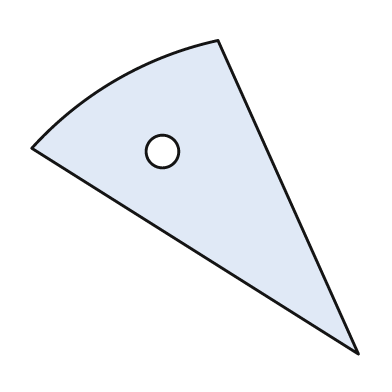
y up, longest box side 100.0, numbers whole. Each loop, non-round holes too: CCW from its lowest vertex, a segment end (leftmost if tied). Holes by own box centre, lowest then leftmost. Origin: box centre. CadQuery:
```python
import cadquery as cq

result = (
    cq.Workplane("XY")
    .moveTo(50.0, -48.0)
    .lineTo(7.0, 48.0)
    .threePointArc((-24.0, 36.0), (-50.0, 15.0))
    .close()
    .moveTo(-10.0, 14.0)
    .circle(5.0)
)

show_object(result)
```